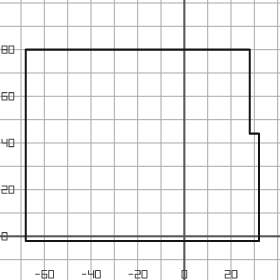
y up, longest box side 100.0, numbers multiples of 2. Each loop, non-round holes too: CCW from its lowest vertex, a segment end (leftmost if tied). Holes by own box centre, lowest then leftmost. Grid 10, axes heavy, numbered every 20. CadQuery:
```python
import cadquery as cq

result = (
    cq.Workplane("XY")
    .moveTo(-68.0, -2.0)
    .lineTo(32.0, -2.0)
    .lineTo(32.0, 44.0)
    .lineTo(28.0, 44.0)
    .lineTo(28.0, 80.0)
    .lineTo(-68.0, 80.0)
    .close()
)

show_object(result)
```